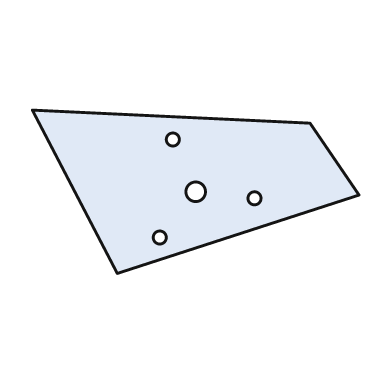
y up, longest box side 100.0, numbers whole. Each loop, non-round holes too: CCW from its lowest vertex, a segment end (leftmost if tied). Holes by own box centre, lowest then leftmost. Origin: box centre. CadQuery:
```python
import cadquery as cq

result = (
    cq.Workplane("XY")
    .moveTo(-24.0, -25.0)
    .lineTo(50.0, -1.0)
    .lineTo(35.0, 21.0)
    .lineTo(-50.0, 25.0)
    .close()
    .moveTo(-11.0, -14.0)
    .circle(2.0)
    .moveTo(18.0, -2.0)
    .circle(2.0)
    .moveTo(0.0, 0.0)
    .circle(3.0)
    .moveTo(-7.0, 16.0)
    .circle(2.0)
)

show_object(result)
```